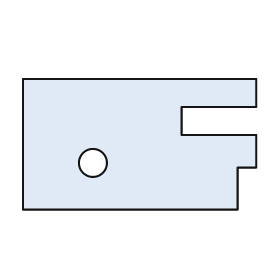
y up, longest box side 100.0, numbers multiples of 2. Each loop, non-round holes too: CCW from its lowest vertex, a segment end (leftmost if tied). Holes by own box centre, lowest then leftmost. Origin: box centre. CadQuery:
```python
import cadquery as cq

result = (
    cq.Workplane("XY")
    .moveTo(-50.0, -28.0)
    .lineTo(42.0, -28.0)
    .lineTo(42.0, -10.0)
    .lineTo(50.0, -10.0)
    .lineTo(50.0, 4.0)
    .lineTo(18.0, 4.0)
    .lineTo(18.0, 16.0)
    .lineTo(50.0, 16.0)
    .lineTo(50.0, 28.0)
    .lineTo(-50.0, 28.0)
    .close()
    .moveTo(-20.0, -8.0)
    .circle(6.0)
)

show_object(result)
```